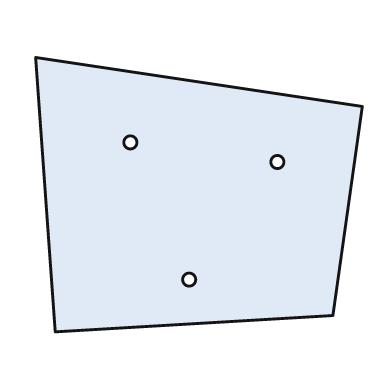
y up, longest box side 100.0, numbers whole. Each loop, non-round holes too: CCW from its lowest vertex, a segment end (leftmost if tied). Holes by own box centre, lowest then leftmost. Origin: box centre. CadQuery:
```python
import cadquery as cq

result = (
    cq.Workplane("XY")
    .moveTo(-44.0, -42.0)
    .lineTo(41.0, -37.0)
    .lineTo(50.0, 27.0)
    .lineTo(-50.0, 42.0)
    .close()
    .moveTo(-3.0, -26.0)
    .circle(2.0)
    .moveTo(24.0, 10.0)
    .circle(2.0)
    .moveTo(-21.0, 16.0)
    .circle(2.0)
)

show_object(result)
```